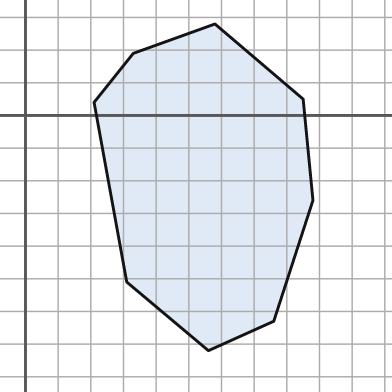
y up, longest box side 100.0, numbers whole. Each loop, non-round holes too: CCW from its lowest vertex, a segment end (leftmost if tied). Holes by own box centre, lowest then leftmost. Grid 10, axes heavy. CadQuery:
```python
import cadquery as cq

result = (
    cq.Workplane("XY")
    .moveTo(56.0, -72.0)
    .lineTo(76.0, -63.0)
    .lineTo(88.0, -26.0)
    .lineTo(85.0, 5.0)
    .lineTo(58.0, 28.0)
    .lineTo(33.0, 19.0)
    .lineTo(21.0, 4.0)
    .lineTo(31.0, -51.0)
    .close()
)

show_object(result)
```